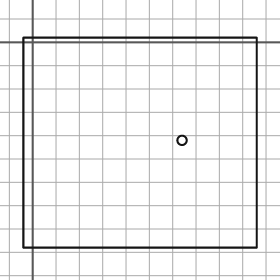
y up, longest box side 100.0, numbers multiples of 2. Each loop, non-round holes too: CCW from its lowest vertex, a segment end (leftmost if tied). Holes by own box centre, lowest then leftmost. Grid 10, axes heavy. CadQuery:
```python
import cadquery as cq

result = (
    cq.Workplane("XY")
    .moveTo(-4.0, -88.0)
    .lineTo(96.0, -88.0)
    .lineTo(96.0, 2.0)
    .lineTo(-4.0, 2.0)
    .close()
    .moveTo(64.0, -42.0)
    .circle(2.0)
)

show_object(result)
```